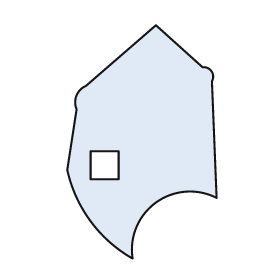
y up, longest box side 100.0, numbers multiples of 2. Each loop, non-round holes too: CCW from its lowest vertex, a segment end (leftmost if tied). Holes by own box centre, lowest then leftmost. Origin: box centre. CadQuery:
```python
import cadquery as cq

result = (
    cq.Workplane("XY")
    .moveTo(-4.0, -50.0)
    .threePointArc((6.0, -26.0), (32.0, -24.0))
    .lineTo(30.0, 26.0)
    .threePointArc((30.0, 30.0), (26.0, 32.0))
    .lineTo(6.0, 50.0)
    .lineTo(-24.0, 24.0)
    .threePointArc((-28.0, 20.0), (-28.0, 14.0))
    .lineTo(-32.0, -12.0)
    .threePointArc((-22.0, -34.0), (-4.0, -50.0))
    .close()
    .moveTo(-22.0, -16.0)
    .lineTo(-10.0, -16.0)
    .lineTo(-10.0, -4.0)
    .lineTo(-22.0, -4.0)
    .close()
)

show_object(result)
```